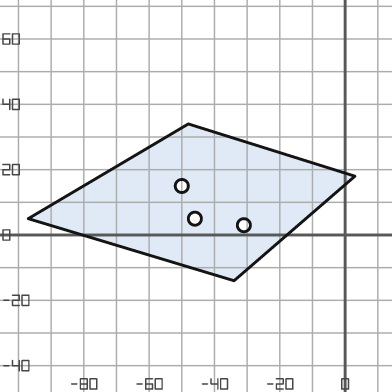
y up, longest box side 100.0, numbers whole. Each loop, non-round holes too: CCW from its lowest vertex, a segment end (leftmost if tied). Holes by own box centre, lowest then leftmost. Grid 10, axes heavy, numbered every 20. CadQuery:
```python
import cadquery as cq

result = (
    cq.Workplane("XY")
    .moveTo(-34.0, -14.0)
    .lineTo(3.0, 18.0)
    .lineTo(-48.0, 34.0)
    .lineTo(-97.0, 5.0)
    .close()
    .moveTo(-31.0, 3.0)
    .circle(2.0)
    .moveTo(-46.0, 5.0)
    .circle(2.0)
    .moveTo(-50.0, 15.0)
    .circle(2.0)
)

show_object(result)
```